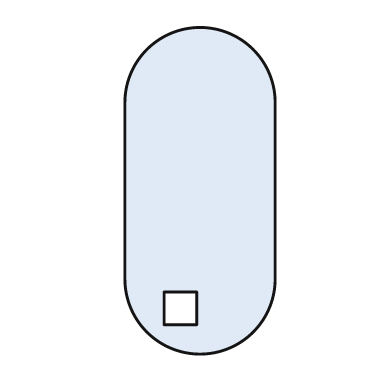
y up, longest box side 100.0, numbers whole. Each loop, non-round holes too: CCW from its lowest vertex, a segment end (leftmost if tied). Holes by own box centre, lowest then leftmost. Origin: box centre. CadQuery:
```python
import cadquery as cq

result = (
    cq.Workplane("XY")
    .moveTo(-23.0, -27.0)
    .threePointArc((0.0, -50.0), (23.0, -27.0))
    .lineTo(23.0, 27.0)
    .threePointArc((0.0, 50.0), (-23.0, 27.0))
    .close()
    .moveTo(-11.0, -41.0)
    .lineTo(-1.0, -41.0)
    .lineTo(-1.0, -31.0)
    .lineTo(-11.0, -31.0)
    .close()
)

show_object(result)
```